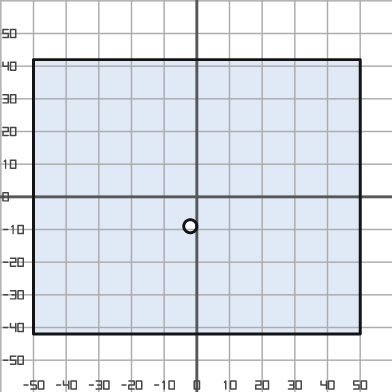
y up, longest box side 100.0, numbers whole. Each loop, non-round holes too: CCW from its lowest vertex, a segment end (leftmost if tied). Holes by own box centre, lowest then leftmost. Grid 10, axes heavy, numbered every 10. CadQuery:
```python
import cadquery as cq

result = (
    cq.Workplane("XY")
    .moveTo(-50.0, -42.0)
    .lineTo(50.0, -42.0)
    .lineTo(50.0, 42.0)
    .lineTo(-50.0, 42.0)
    .close()
    .moveTo(-2.0, -9.0)
    .circle(2.0)
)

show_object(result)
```